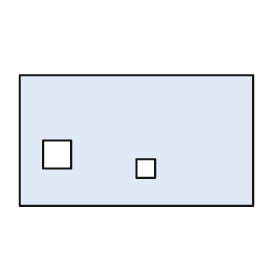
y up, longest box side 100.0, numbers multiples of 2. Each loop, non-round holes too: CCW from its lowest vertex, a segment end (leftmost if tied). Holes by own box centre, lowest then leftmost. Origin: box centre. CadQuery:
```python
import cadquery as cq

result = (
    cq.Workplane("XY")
    .moveTo(-50.0, -28.0)
    .lineTo(50.0, -28.0)
    .lineTo(50.0, 28.0)
    .lineTo(-50.0, 28.0)
    .close()
    .moveTo(0.0, -16.0)
    .lineTo(8.0, -16.0)
    .lineTo(8.0, -8.0)
    .lineTo(0.0, -8.0)
    .close()
    .moveTo(-40.0, -12.0)
    .lineTo(-28.0, -12.0)
    .lineTo(-28.0, 0.0)
    .lineTo(-40.0, 0.0)
    .close()
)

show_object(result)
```